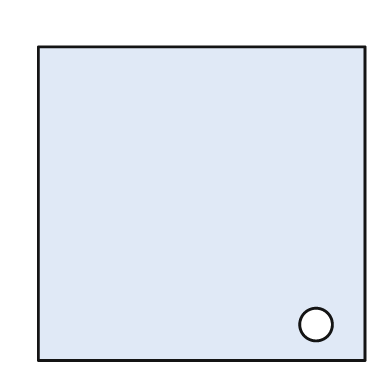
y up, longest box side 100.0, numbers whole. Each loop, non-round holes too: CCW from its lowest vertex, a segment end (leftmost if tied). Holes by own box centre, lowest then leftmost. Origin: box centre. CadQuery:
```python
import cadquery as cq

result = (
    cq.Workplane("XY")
    .moveTo(-50.0, -48.0)
    .lineTo(50.0, -48.0)
    .lineTo(50.0, 48.0)
    .lineTo(-50.0, 48.0)
    .close()
    .moveTo(35.0, -37.0)
    .circle(5.0)
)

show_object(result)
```